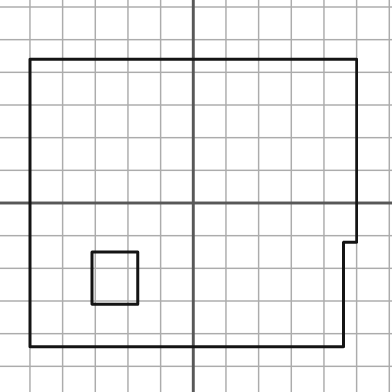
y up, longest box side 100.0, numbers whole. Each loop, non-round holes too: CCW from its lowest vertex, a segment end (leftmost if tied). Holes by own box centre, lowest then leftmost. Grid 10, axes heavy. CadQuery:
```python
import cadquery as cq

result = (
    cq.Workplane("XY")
    .moveTo(-50.0, -44.0)
    .lineTo(46.0, -44.0)
    .lineTo(46.0, -12.0)
    .lineTo(50.0, -12.0)
    .lineTo(50.0, 44.0)
    .lineTo(-50.0, 44.0)
    .close()
    .moveTo(-31.0, -31.0)
    .lineTo(-17.0, -31.0)
    .lineTo(-17.0, -15.0)
    .lineTo(-31.0, -15.0)
    .close()
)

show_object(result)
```